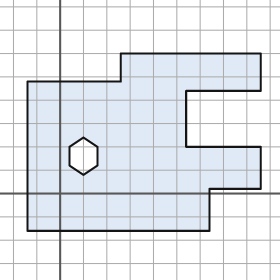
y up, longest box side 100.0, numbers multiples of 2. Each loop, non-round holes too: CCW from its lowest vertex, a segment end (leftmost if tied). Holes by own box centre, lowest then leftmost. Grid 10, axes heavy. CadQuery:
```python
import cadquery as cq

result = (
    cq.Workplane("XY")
    .moveTo(-14.0, -16.0)
    .lineTo(64.0, -16.0)
    .lineTo(64.0, 2.0)
    .lineTo(86.0, 2.0)
    .lineTo(86.0, 20.0)
    .lineTo(54.0, 20.0)
    .lineTo(54.0, 44.0)
    .lineTo(86.0, 44.0)
    .lineTo(86.0, 60.0)
    .lineTo(26.0, 60.0)
    .lineTo(26.0, 48.0)
    .lineTo(-14.0, 48.0)
    .close()
    .moveTo(10.0, 8.0)
    .lineTo(16.0, 12.0)
    .lineTo(16.0, 20.0)
    .lineTo(10.0, 24.0)
    .lineTo(4.0, 20.0)
    .lineTo(4.0, 12.0)
    .close()
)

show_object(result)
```